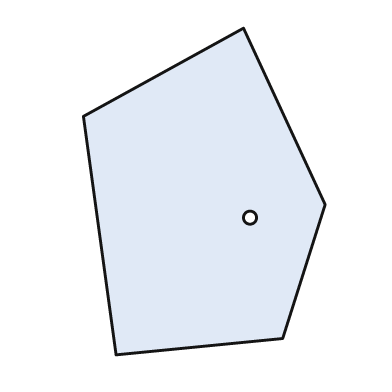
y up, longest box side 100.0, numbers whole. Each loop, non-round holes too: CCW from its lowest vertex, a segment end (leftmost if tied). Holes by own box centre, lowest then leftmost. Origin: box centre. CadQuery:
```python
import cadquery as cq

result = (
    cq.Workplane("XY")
    .moveTo(-27.0, -50.0)
    .lineTo(24.0, -45.0)
    .lineTo(37.0, -4.0)
    .lineTo(12.0, 50.0)
    .lineTo(-37.0, 23.0)
    .close()
    .moveTo(14.0, -8.0)
    .circle(2.0)
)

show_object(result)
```